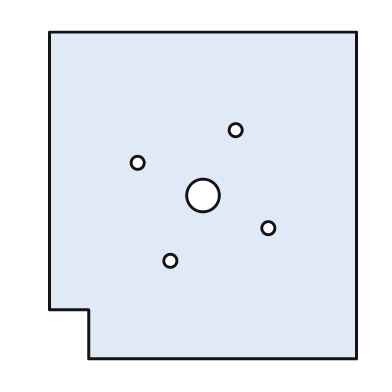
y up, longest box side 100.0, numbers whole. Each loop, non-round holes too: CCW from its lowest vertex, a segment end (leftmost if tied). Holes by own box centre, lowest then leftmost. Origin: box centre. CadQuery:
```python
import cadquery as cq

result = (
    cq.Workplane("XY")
    .moveTo(-35.0, -50.0)
    .lineTo(47.0, -50.0)
    .lineTo(47.0, 50.0)
    .lineTo(-47.0, 50.0)
    .lineTo(-47.0, -35.0)
    .lineTo(-35.0, -35.0)
    .close()
    .moveTo(-10.0, -20.0)
    .circle(2.0)
    .moveTo(20.0, -10.0)
    .circle(2.0)
    .moveTo(0.0, 0.0)
    .circle(5.0)
    .moveTo(-20.0, 10.0)
    .circle(2.0)
    .moveTo(10.0, 20.0)
    .circle(2.0)
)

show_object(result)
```